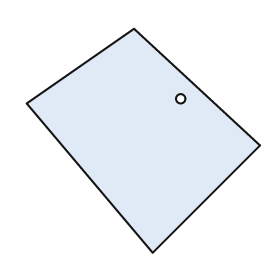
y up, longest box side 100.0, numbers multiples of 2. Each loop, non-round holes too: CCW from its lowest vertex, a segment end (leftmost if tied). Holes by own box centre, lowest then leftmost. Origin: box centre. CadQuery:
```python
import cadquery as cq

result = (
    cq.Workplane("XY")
    .moveTo(4.0, -48.0)
    .lineTo(50.0, -2.0)
    .lineTo(-4.0, 48.0)
    .lineTo(-50.0, 16.0)
    .close()
    .moveTo(16.0, 18.0)
    .circle(2.0)
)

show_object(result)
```